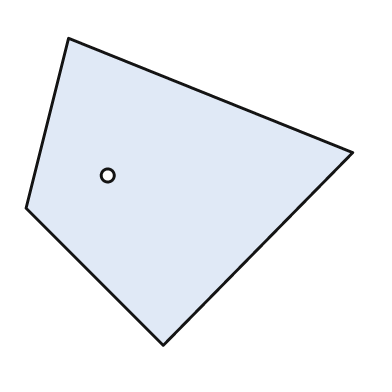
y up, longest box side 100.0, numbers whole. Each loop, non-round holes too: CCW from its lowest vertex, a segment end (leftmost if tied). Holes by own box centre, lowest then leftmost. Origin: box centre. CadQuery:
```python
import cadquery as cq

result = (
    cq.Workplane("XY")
    .moveTo(-8.0, -47.0)
    .lineTo(50.0, 12.0)
    .lineTo(-37.0, 47.0)
    .lineTo(-50.0, -5.0)
    .close()
    .moveTo(-25.0, 5.0)
    .circle(2.0)
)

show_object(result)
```